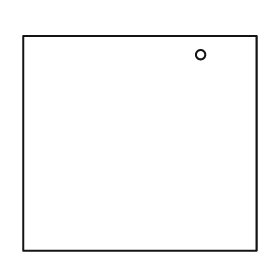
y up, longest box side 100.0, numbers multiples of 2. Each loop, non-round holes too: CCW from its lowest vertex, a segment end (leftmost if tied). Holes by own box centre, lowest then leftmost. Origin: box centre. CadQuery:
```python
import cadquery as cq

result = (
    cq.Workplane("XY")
    .moveTo(-50.0, -46.0)
    .lineTo(50.0, -46.0)
    .lineTo(50.0, 46.0)
    .lineTo(-50.0, 46.0)
    .close()
    .moveTo(26.0, 38.0)
    .circle(2.0)
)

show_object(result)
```